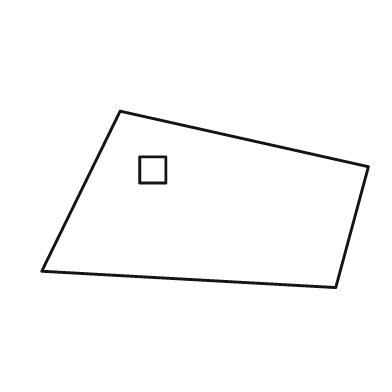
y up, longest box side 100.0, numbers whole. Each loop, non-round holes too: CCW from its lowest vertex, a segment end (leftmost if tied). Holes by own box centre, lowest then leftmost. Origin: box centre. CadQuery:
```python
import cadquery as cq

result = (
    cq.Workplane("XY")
    .moveTo(40.0, -27.0)
    .lineTo(50.0, 10.0)
    .lineTo(-26.0, 27.0)
    .lineTo(-50.0, -22.0)
    .close()
    .moveTo(-20.0, 5.0)
    .lineTo(-12.0, 5.0)
    .lineTo(-12.0, 13.0)
    .lineTo(-20.0, 13.0)
    .close()
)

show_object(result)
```